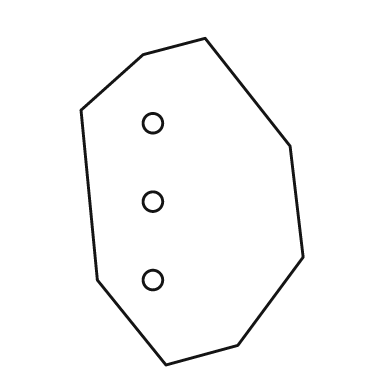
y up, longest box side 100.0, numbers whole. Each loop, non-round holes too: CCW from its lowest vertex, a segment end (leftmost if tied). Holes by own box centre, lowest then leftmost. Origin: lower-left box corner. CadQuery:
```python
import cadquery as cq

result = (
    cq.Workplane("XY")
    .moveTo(26.0, 0.0)
    .lineTo(48.0, 6.0)
    .lineTo(68.0, 33.0)
    .lineTo(64.0, 67.0)
    .lineTo(38.0, 100.0)
    .lineTo(19.0, 95.0)
    .lineTo(0.0, 78.0)
    .lineTo(5.0, 26.0)
    .close()
    .moveTo(22.0, 26.0)
    .circle(3.0)
    .moveTo(22.0, 50.0)
    .circle(3.0)
    .moveTo(22.0, 74.0)
    .circle(3.0)
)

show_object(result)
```